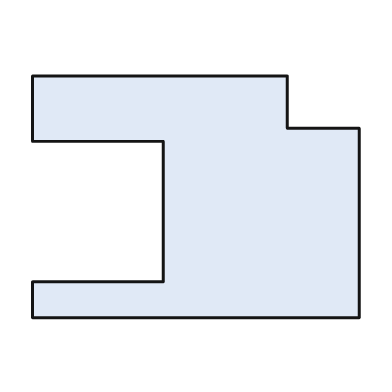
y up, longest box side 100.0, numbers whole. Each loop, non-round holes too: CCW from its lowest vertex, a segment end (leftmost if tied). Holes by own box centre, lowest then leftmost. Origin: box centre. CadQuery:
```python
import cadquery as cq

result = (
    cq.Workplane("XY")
    .moveTo(-50.0, -37.0)
    .lineTo(50.0, -37.0)
    .lineTo(50.0, 21.0)
    .lineTo(28.0, 21.0)
    .lineTo(28.0, 37.0)
    .lineTo(-50.0, 37.0)
    .lineTo(-50.0, 17.0)
    .lineTo(-10.0, 17.0)
    .lineTo(-10.0, -26.0)
    .lineTo(-50.0, -26.0)
    .close()
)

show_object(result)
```